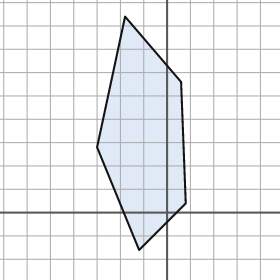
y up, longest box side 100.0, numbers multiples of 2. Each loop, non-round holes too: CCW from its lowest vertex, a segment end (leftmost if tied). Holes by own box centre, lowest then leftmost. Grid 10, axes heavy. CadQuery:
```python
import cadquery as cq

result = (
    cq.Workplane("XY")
    .moveTo(-12.0, -16.0)
    .lineTo(8.0, 4.0)
    .lineTo(6.0, 56.0)
    .lineTo(-18.0, 84.0)
    .lineTo(-30.0, 28.0)
    .close()
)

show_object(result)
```